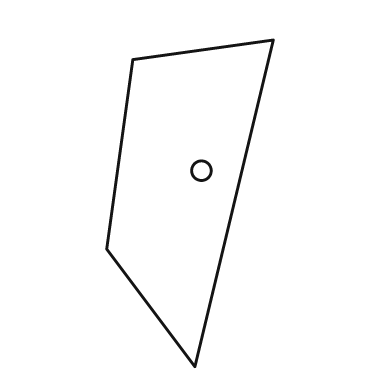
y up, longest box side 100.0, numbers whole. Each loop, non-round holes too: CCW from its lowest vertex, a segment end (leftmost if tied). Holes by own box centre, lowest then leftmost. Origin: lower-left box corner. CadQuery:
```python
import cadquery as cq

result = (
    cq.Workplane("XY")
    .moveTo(27.0, 0.0)
    .lineTo(51.0, 100.0)
    .lineTo(8.0, 94.0)
    .lineTo(0.0, 36.0)
    .close()
    .moveTo(29.0, 60.0)
    .circle(3.0)
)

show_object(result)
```